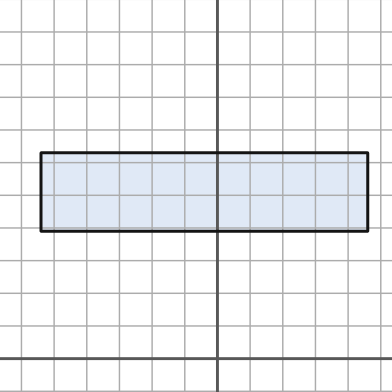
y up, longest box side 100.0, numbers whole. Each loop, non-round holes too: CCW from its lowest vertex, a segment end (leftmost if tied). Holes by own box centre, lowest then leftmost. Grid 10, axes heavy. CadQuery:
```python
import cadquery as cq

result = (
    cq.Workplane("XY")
    .moveTo(-54.0, 39.0)
    .lineTo(46.0, 39.0)
    .lineTo(46.0, 63.0)
    .lineTo(-54.0, 63.0)
    .close()
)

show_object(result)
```